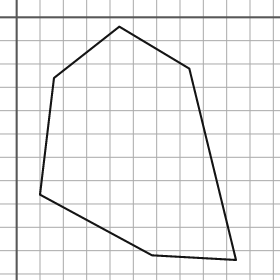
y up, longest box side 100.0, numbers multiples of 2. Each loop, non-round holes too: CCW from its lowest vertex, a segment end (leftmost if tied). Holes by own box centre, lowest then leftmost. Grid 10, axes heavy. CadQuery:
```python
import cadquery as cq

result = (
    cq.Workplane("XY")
    .moveTo(94.0, -104.0)
    .lineTo(74.0, -22.0)
    .lineTo(44.0, -4.0)
    .lineTo(16.0, -26.0)
    .lineTo(10.0, -76.0)
    .lineTo(58.0, -102.0)
    .close()
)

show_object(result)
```